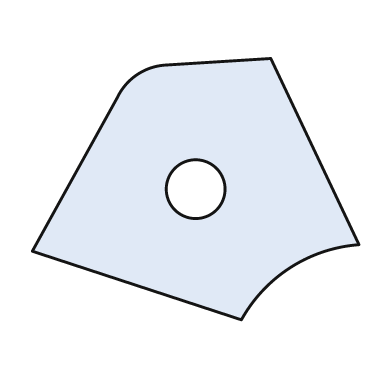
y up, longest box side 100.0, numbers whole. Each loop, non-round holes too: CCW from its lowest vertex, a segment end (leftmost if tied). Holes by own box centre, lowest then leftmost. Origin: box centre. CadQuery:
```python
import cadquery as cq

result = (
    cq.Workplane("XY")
    .moveTo(14.0, -40.0)
    .threePointArc((29.0, -24.0), (50.0, -17.0))
    .lineTo(23.0, 40.0)
    .lineTo(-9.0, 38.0)
    .threePointArc((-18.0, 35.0), (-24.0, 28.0))
    .lineTo(-50.0, -19.0)
    .close()
    .moveTo(0.0, 0.0)
    .circle(9.0)
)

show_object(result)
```